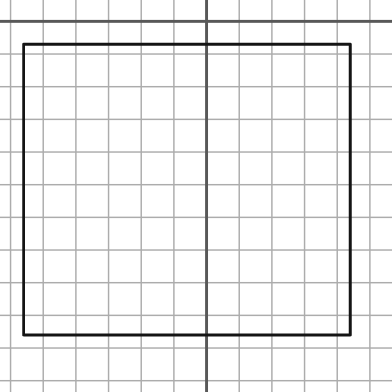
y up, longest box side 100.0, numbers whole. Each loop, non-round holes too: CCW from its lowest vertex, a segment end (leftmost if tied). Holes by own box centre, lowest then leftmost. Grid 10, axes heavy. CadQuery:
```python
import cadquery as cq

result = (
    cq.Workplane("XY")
    .moveTo(-56.0, -96.0)
    .lineTo(44.0, -96.0)
    .lineTo(44.0, -7.0)
    .lineTo(-56.0, -7.0)
    .close()
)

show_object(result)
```